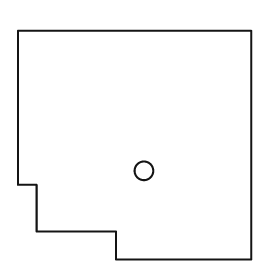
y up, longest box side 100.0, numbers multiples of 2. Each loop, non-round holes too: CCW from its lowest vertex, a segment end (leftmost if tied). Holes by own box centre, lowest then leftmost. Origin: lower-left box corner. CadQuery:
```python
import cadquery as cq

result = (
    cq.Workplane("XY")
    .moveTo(42.0, 0.0)
    .lineTo(100.0, 0.0)
    .lineTo(100.0, 98.0)
    .lineTo(0.0, 98.0)
    .lineTo(0.0, 32.0)
    .lineTo(8.0, 32.0)
    .lineTo(8.0, 12.0)
    .lineTo(42.0, 12.0)
    .close()
    .moveTo(54.0, 38.0)
    .circle(4.0)
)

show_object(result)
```